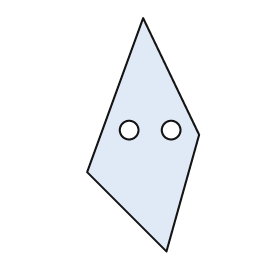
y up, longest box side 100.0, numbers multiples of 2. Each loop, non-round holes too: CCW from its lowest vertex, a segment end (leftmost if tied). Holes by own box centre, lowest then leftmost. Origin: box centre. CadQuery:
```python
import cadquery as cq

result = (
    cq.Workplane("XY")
    .moveTo(10.0, -50.0)
    .lineTo(24.0, 0.0)
    .lineTo(0.0, 50.0)
    .lineTo(-24.0, -16.0)
    .close()
    .moveTo(-6.0, 2.0)
    .circle(4.0)
    .moveTo(12.0, 2.0)
    .circle(4.0)
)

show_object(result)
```